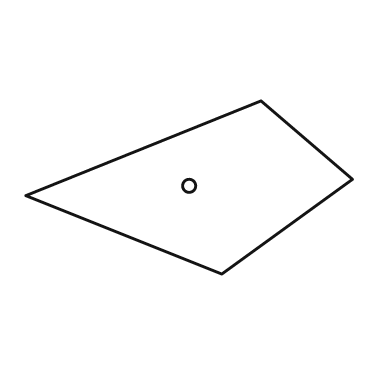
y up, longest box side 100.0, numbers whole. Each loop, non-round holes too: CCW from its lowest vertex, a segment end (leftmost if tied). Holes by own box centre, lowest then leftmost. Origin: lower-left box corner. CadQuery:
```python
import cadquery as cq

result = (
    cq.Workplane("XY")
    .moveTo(60.0, 0.0)
    .lineTo(100.0, 29.0)
    .lineTo(72.0, 53.0)
    .lineTo(0.0, 24.0)
    .close()
    .moveTo(50.0, 27.0)
    .circle(2.0)
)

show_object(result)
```